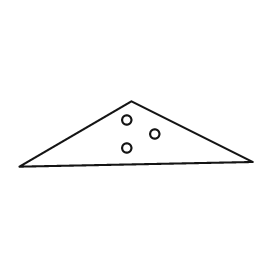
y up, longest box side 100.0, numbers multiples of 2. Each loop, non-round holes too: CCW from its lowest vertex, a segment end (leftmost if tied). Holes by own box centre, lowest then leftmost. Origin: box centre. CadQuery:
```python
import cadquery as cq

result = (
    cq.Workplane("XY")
    .moveTo(-50.0, -14.0)
    .lineTo(50.0, -12.0)
    .lineTo(-2.0, 14.0)
    .close()
    .moveTo(-4.0, -6.0)
    .circle(2.0)
    .moveTo(8.0, 0.0)
    .circle(2.0)
    .moveTo(-4.0, 6.0)
    .circle(2.0)
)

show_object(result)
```